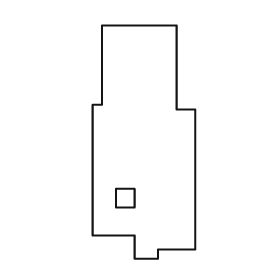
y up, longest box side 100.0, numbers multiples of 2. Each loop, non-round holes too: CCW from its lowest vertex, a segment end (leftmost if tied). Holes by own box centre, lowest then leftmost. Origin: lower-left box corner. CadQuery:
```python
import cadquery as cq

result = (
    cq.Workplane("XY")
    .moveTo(18.0, 0.0)
    .lineTo(28.0, 0.0)
    .lineTo(28.0, 4.0)
    .lineTo(44.0, 4.0)
    .lineTo(44.0, 64.0)
    .lineTo(36.0, 64.0)
    .lineTo(36.0, 100.0)
    .lineTo(4.0, 100.0)
    .lineTo(4.0, 66.0)
    .lineTo(0.0, 66.0)
    .lineTo(0.0, 10.0)
    .lineTo(18.0, 10.0)
    .close()
    .moveTo(10.0, 22.0)
    .lineTo(18.0, 22.0)
    .lineTo(18.0, 30.0)
    .lineTo(10.0, 30.0)
    .close()
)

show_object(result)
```